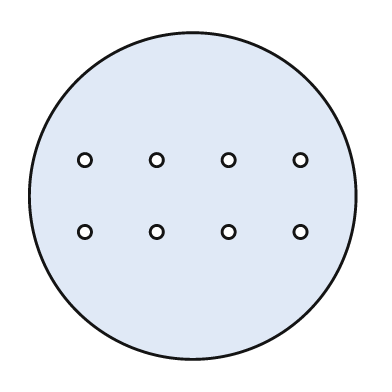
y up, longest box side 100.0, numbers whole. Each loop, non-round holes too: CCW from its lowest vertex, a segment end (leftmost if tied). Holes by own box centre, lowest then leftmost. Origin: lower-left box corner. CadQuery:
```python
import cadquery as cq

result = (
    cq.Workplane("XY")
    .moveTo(50.0, 50.0)
    .circle(50.0)
    .moveTo(17.0, 39.0)
    .circle(2.0)
    .moveTo(39.0, 39.0)
    .circle(2.0)
    .moveTo(61.0, 39.0)
    .circle(2.0)
    .moveTo(83.0, 39.0)
    .circle(2.0)
    .moveTo(17.0, 61.0)
    .circle(2.0)
    .moveTo(39.0, 61.0)
    .circle(2.0)
    .moveTo(61.0, 61.0)
    .circle(2.0)
    .moveTo(83.0, 61.0)
    .circle(2.0)
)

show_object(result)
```